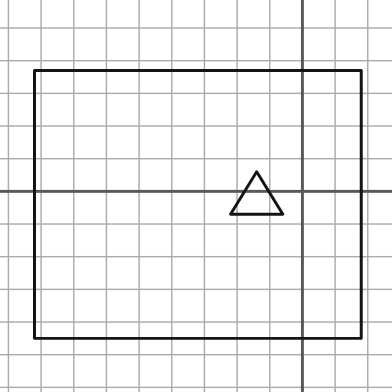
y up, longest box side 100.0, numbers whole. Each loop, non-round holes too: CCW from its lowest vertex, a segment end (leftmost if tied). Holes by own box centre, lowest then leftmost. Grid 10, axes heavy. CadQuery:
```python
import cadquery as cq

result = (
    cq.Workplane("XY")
    .moveTo(-82.0, -45.0)
    .lineTo(18.0, -45.0)
    .lineTo(18.0, 37.0)
    .lineTo(-82.0, 37.0)
    .close()
    .moveTo(-22.0, -7.0)
    .lineTo(-6.0, -7.0)
    .lineTo(-14.0, 6.0)
    .close()
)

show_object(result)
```